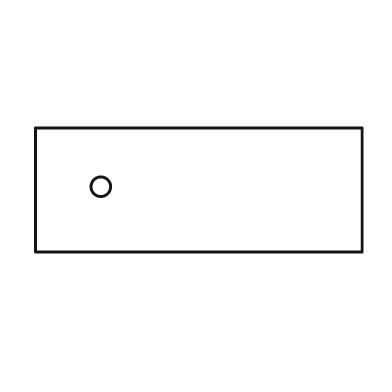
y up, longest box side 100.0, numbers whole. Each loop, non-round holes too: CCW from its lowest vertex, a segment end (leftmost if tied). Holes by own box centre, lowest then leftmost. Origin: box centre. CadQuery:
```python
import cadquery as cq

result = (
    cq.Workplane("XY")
    .moveTo(-50.0, -19.0)
    .lineTo(50.0, -19.0)
    .lineTo(50.0, 19.0)
    .lineTo(-50.0, 19.0)
    .close()
    .moveTo(-30.0, 1.0)
    .circle(3.0)
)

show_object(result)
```